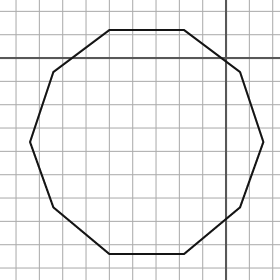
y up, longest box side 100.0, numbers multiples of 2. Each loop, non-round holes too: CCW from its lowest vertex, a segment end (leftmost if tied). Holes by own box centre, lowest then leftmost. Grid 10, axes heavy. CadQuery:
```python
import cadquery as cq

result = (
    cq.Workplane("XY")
    .moveTo(-50.0, -84.0)
    .lineTo(-18.0, -84.0)
    .lineTo(6.0, -64.0)
    .lineTo(16.0, -36.0)
    .lineTo(6.0, -6.0)
    .lineTo(-18.0, 12.0)
    .lineTo(-50.0, 12.0)
    .lineTo(-74.0, -6.0)
    .lineTo(-84.0, -36.0)
    .lineTo(-74.0, -64.0)
    .close()
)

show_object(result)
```